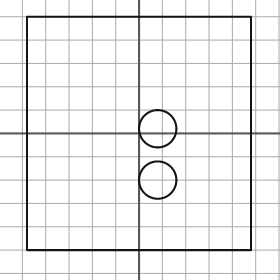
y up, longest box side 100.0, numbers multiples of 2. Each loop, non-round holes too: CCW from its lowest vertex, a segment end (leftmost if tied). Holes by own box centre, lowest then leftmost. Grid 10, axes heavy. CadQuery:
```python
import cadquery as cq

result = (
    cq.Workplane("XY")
    .moveTo(-48.0, -50.0)
    .lineTo(48.0, -50.0)
    .lineTo(48.0, 50.0)
    .lineTo(-48.0, 50.0)
    .close()
    .moveTo(8.0, -20.0)
    .circle(8.0)
    .moveTo(8.0, 2.0)
    .circle(8.0)
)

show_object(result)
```